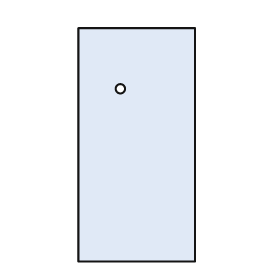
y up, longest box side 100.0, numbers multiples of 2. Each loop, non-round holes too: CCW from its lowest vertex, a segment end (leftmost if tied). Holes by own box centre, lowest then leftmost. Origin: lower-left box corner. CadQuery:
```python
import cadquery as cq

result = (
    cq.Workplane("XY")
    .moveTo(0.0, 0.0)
    .lineTo(50.0, 0.0)
    .lineTo(50.0, 100.0)
    .lineTo(0.0, 100.0)
    .close()
    .moveTo(18.0, 74.0)
    .circle(2.0)
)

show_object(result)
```